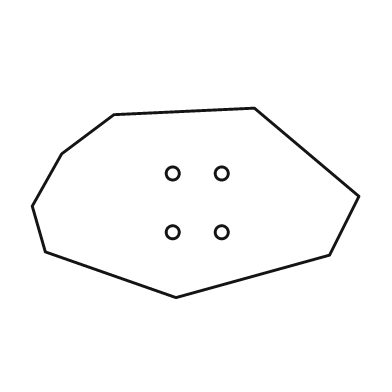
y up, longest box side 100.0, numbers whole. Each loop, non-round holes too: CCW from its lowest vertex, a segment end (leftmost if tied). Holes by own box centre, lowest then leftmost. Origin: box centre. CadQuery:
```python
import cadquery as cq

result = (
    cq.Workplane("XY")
    .moveTo(-6.0, -29.0)
    .lineTo(41.0, -16.0)
    .lineTo(50.0, 2.0)
    .lineTo(18.0, 29.0)
    .lineTo(-25.0, 27.0)
    .lineTo(-41.0, 15.0)
    .lineTo(-50.0, -1.0)
    .lineTo(-46.0, -15.0)
    .close()
    .moveTo(-7.0, -9.0)
    .circle(2.0)
    .moveTo(8.0, -9.0)
    .circle(2.0)
    .moveTo(-7.0, 9.0)
    .circle(2.0)
    .moveTo(8.0, 9.0)
    .circle(2.0)
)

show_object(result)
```